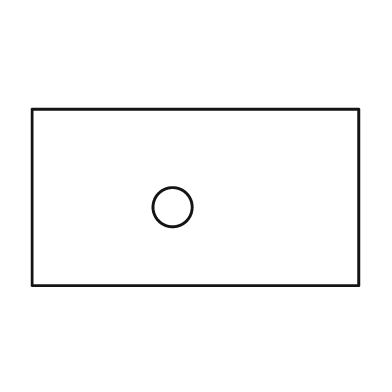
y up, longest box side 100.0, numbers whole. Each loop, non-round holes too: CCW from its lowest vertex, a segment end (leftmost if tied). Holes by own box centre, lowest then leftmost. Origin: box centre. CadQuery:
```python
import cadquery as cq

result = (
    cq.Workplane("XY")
    .moveTo(-50.0, -27.0)
    .lineTo(50.0, -27.0)
    .lineTo(50.0, 27.0)
    .lineTo(-50.0, 27.0)
    .close()
    .moveTo(-7.0, -3.0)
    .circle(6.0)
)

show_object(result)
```